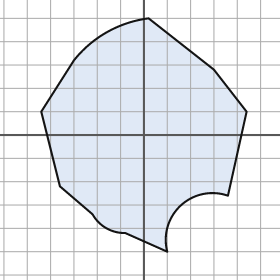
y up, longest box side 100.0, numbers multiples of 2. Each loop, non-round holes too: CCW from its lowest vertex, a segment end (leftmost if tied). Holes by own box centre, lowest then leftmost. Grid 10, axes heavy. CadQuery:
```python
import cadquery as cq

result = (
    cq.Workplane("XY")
    .moveTo(10.0, -50.0)
    .threePointArc((16.0, -30.0), (36.0, -26.0))
    .lineTo(44.0, 10.0)
    .lineTo(30.0, 28.0)
    .lineTo(2.0, 50.0)
    .threePointArc((-16.0, 44.0), (-30.0, 32.0))
    .lineTo(-44.0, 10.0)
    .lineTo(-36.0, -22.0)
    .lineTo(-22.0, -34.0)
    .threePointArc((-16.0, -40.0), (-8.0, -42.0))
    .close()
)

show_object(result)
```